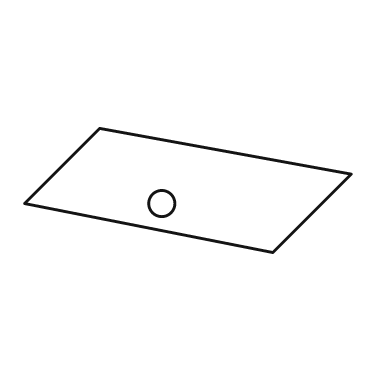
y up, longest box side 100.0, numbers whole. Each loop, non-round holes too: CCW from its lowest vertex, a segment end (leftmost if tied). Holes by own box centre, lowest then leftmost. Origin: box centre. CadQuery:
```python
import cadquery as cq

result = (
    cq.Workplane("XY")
    .moveTo(26.0, -19.0)
    .lineTo(50.0, 5.0)
    .lineTo(-27.0, 19.0)
    .lineTo(-50.0, -4.0)
    .close()
    .moveTo(-8.0, -4.0)
    .circle(4.0)
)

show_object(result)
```